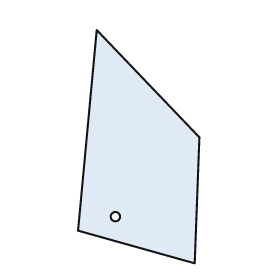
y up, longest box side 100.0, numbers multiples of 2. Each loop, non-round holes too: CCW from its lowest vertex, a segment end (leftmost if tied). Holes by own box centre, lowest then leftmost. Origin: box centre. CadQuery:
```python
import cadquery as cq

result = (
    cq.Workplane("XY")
    .moveTo(24.0, -50.0)
    .lineTo(26.0, 4.0)
    .lineTo(-18.0, 50.0)
    .lineTo(-26.0, -36.0)
    .close()
    .moveTo(-10.0, -30.0)
    .circle(2.0)
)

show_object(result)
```